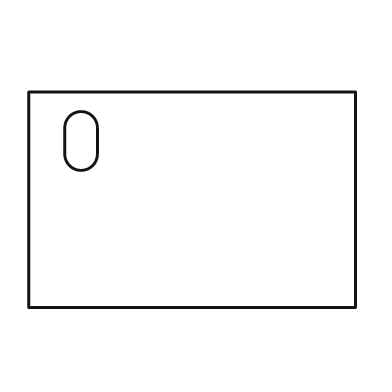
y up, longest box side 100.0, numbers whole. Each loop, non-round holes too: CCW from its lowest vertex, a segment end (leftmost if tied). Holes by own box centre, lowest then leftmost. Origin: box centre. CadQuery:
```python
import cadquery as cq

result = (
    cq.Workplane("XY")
    .moveTo(-50.0, -33.0)
    .lineTo(50.0, -33.0)
    .lineTo(50.0, 33.0)
    .lineTo(-50.0, 33.0)
    .close()
    .moveTo(-39.0, 14.0)
    .threePointArc((-34.0, 9.0), (-29.0, 14.0))
    .lineTo(-29.0, 22.0)
    .threePointArc((-34.0, 27.0), (-39.0, 22.0))
    .close()
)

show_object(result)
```